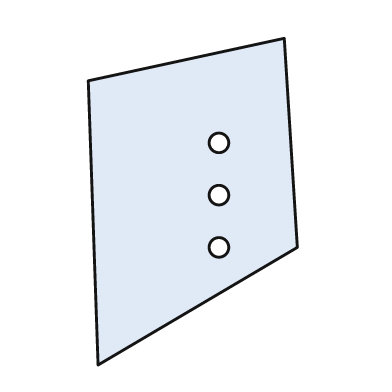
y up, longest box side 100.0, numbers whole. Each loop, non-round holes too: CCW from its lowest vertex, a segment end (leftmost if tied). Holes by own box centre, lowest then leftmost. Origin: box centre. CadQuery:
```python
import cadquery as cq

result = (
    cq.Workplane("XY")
    .moveTo(-29.0, -50.0)
    .lineTo(32.0, -14.0)
    .lineTo(28.0, 50.0)
    .lineTo(-32.0, 37.0)
    .close()
    .moveTo(8.0, -14.0)
    .circle(3.0)
    .moveTo(8.0, 2.0)
    .circle(3.0)
    .moveTo(8.0, 18.0)
    .circle(3.0)
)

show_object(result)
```